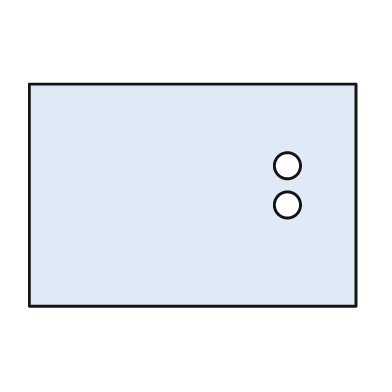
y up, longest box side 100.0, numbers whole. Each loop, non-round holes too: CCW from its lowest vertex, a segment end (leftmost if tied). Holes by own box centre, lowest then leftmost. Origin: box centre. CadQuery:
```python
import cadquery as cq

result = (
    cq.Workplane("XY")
    .moveTo(-50.0, -34.0)
    .lineTo(50.0, -34.0)
    .lineTo(50.0, 34.0)
    .lineTo(-50.0, 34.0)
    .close()
    .moveTo(29.0, -3.0)
    .circle(4.0)
    .moveTo(29.0, 9.0)
    .circle(4.0)
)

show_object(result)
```